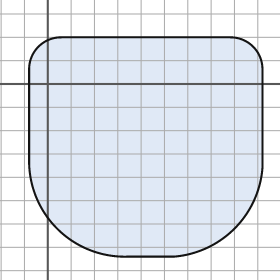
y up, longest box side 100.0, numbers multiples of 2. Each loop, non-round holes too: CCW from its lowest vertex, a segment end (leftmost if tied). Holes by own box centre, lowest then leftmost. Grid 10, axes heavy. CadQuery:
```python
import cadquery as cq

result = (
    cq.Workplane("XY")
    .moveTo(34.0, -74.0)
    .lineTo(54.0, -74.0)
    .threePointArc((80.0, -62.0), (92.0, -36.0))
    .lineTo(92.0, 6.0)
    .threePointArc((88.0, 16.0), (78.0, 20.0))
    .lineTo(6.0, 20.0)
    .threePointArc((-4.0, 16.0), (-8.0, 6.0))
    .lineTo(-8.0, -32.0)
    .threePointArc((4.0, -62.0), (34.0, -74.0))
    .close()
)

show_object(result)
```